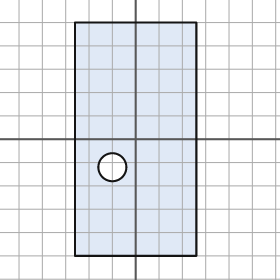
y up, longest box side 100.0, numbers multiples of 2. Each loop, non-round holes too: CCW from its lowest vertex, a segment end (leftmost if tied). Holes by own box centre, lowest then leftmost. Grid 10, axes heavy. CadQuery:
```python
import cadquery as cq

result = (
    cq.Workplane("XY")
    .moveTo(-26.0, -50.0)
    .lineTo(26.0, -50.0)
    .lineTo(26.0, 50.0)
    .lineTo(-26.0, 50.0)
    .close()
    .moveTo(-10.0, -12.0)
    .circle(6.0)
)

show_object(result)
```